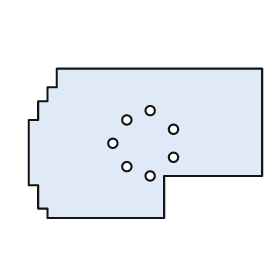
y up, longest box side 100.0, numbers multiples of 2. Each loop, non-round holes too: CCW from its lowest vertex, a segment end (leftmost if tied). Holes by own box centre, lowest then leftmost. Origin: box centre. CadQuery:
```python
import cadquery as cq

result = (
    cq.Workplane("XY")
    .moveTo(-42.0, -32.0)
    .lineTo(8.0, -32.0)
    .lineTo(8.0, -14.0)
    .lineTo(50.0, -14.0)
    .lineTo(50.0, 32.0)
    .lineTo(-38.0, 32.0)
    .lineTo(-38.0, 24.0)
    .lineTo(-42.0, 24.0)
    .lineTo(-42.0, 18.0)
    .lineTo(-46.0, 18.0)
    .lineTo(-46.0, 10.0)
    .lineTo(-50.0, 10.0)
    .lineTo(-50.0, -18.0)
    .lineTo(-46.0, -18.0)
    .lineTo(-46.0, -28.0)
    .lineTo(-42.0, -28.0)
    .close()
    .moveTo(2.0, -14.0)
    .circle(2.0)
    .moveTo(-8.0, -10.0)
    .circle(2.0)
    .moveTo(12.0, -6.0)
    .circle(2.0)
    .moveTo(-14.0, 0.0)
    .circle(2.0)
    .moveTo(12.0, 6.0)
    .circle(2.0)
    .moveTo(-8.0, 10.0)
    .circle(2.0)
    .moveTo(2.0, 14.0)
    .circle(2.0)
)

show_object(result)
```